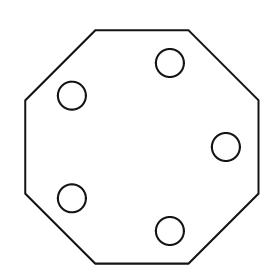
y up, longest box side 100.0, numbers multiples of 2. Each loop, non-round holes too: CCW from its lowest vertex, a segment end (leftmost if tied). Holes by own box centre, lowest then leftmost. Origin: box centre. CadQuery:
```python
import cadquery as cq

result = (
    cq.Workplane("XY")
    .moveTo(-20.0, -50.0)
    .lineTo(20.0, -50.0)
    .lineTo(50.0, -20.0)
    .lineTo(50.0, 20.0)
    .lineTo(20.0, 50.0)
    .lineTo(-20.0, 50.0)
    .lineTo(-50.0, 20.0)
    .lineTo(-50.0, -20.0)
    .close()
    .moveTo(12.0, -36.0)
    .circle(6.0)
    .moveTo(-30.0, -22.0)
    .circle(6.0)
    .moveTo(36.0, 0.0)
    .circle(6.0)
    .moveTo(-30.0, 22.0)
    .circle(6.0)
    .moveTo(12.0, 36.0)
    .circle(6.0)
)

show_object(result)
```